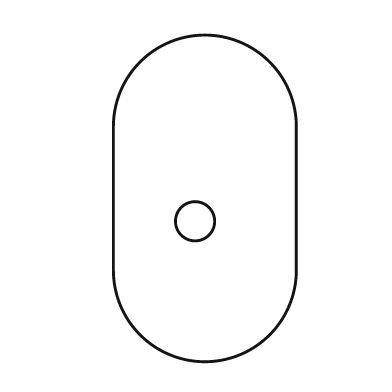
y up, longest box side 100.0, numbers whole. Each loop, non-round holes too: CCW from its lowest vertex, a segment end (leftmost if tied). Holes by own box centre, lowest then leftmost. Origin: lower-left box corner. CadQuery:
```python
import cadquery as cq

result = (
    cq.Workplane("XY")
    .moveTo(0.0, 28.0)
    .threePointArc((28.0, 0.0), (56.0, 28.0))
    .lineTo(56.0, 72.0)
    .threePointArc((28.0, 100.0), (0.0, 72.0))
    .close()
    .moveTo(25.0, 43.0)
    .circle(6.0)
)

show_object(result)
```